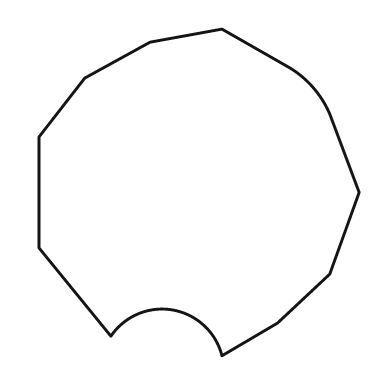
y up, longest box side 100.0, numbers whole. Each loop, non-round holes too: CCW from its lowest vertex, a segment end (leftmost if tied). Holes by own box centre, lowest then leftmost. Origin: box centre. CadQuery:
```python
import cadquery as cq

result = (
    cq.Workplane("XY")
    .moveTo(7.0, -50.0)
    .lineTo(24.0, -40.0)
    .lineTo(40.0, -25.0)
    .lineTo(49.0, 0.0)
    .lineTo(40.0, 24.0)
    .threePointArc((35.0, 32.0), (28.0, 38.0))
    .lineTo(7.0, 50.0)
    .lineTo(-15.0, 46.0)
    .lineTo(-35.0, 35.0)
    .lineTo(-49.0, 17.0)
    .lineTo(-49.0, -17.0)
    .lineTo(-27.0, -44.0)
    .threePointArc((-8.0, -36.0), (7.0, -50.0))
    .close()
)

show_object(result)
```